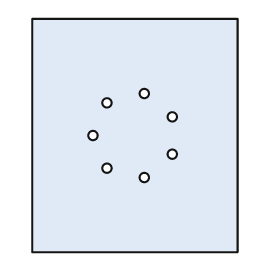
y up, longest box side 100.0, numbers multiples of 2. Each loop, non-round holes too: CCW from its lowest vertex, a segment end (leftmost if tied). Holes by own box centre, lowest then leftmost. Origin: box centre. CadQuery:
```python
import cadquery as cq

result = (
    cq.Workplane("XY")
    .moveTo(-44.0, -50.0)
    .lineTo(44.0, -50.0)
    .lineTo(44.0, 50.0)
    .lineTo(-44.0, 50.0)
    .close()
    .moveTo(4.0, -18.0)
    .circle(2.0)
    .moveTo(-12.0, -14.0)
    .circle(2.0)
    .moveTo(16.0, -8.0)
    .circle(2.0)
    .moveTo(-18.0, 0.0)
    .circle(2.0)
    .moveTo(16.0, 8.0)
    .circle(2.0)
    .moveTo(-12.0, 14.0)
    .circle(2.0)
    .moveTo(4.0, 18.0)
    .circle(2.0)
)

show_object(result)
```